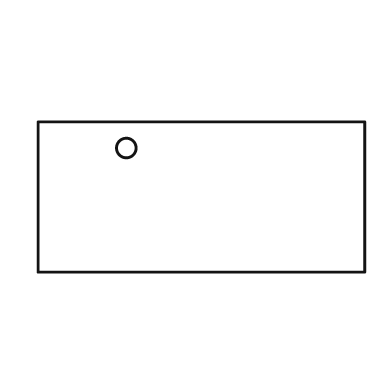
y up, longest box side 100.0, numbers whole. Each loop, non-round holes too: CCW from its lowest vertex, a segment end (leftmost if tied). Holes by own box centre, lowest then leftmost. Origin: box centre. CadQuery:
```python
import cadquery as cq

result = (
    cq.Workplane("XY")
    .moveTo(-50.0, -23.0)
    .lineTo(50.0, -23.0)
    .lineTo(50.0, 23.0)
    .lineTo(-50.0, 23.0)
    .close()
    .moveTo(-23.0, 15.0)
    .circle(3.0)
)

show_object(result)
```